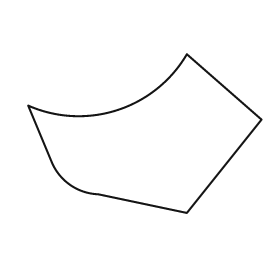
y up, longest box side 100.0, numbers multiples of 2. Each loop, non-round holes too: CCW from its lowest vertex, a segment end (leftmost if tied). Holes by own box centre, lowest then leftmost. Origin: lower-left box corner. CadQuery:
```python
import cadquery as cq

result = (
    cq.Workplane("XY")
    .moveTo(68.0, 0.0)
    .lineTo(100.0, 40.0)
    .lineTo(68.0, 68.0)
    .threePointArc((38.0, 44.0), (0.0, 46.0))
    .lineTo(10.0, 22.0)
    .threePointArc((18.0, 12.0), (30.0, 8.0))
    .close()
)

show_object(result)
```